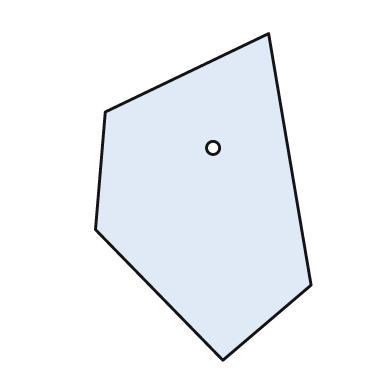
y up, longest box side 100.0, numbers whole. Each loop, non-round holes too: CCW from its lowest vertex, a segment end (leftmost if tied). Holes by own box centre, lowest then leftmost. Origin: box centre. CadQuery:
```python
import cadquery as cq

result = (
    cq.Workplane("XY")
    .moveTo(6.0, -50.0)
    .lineTo(33.0, -27.0)
    .lineTo(20.0, 50.0)
    .lineTo(-30.0, 26.0)
    .lineTo(-33.0, -10.0)
    .close()
    .moveTo(3.0, 15.0)
    .circle(2.0)
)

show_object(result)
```